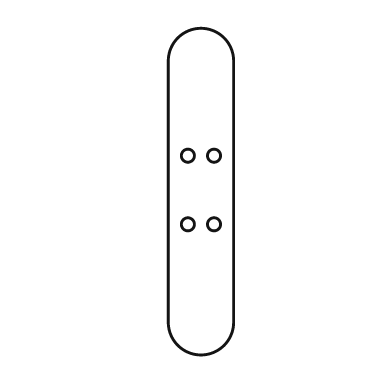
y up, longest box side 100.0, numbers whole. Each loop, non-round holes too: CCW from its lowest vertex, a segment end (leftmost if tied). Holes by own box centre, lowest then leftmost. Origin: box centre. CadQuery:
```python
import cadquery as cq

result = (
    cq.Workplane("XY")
    .moveTo(-10.0, -40.0)
    .threePointArc((0.0, -50.0), (10.0, -40.0))
    .lineTo(10.0, 40.0)
    .threePointArc((0.0, 50.0), (-10.0, 40.0))
    .close()
    .moveTo(-4.0, -10.0)
    .circle(2.0)
    .moveTo(4.0, -10.0)
    .circle(2.0)
    .moveTo(-4.0, 11.0)
    .circle(2.0)
    .moveTo(4.0, 11.0)
    .circle(2.0)
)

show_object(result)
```